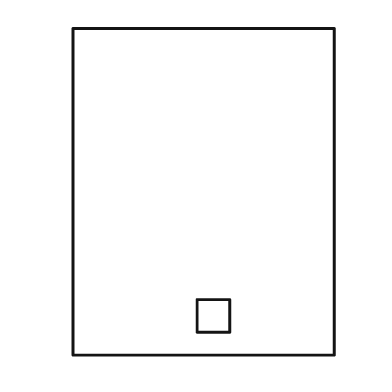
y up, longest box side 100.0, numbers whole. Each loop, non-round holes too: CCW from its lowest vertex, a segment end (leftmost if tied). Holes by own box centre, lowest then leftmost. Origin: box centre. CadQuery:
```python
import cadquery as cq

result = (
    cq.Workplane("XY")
    .moveTo(-40.0, -50.0)
    .lineTo(40.0, -50.0)
    .lineTo(40.0, 50.0)
    .lineTo(-40.0, 50.0)
    .close()
    .moveTo(-2.0, -43.0)
    .lineTo(8.0, -43.0)
    .lineTo(8.0, -33.0)
    .lineTo(-2.0, -33.0)
    .close()
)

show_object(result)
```